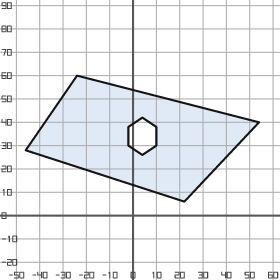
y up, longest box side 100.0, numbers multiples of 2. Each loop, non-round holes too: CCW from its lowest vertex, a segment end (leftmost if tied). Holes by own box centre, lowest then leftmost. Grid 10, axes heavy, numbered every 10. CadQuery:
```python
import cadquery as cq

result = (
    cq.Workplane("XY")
    .moveTo(22.0, 6.0)
    .lineTo(54.0, 40.0)
    .lineTo(-24.0, 60.0)
    .lineTo(-46.0, 28.0)
    .close()
    .moveTo(4.0, 26.0)
    .lineTo(10.0, 30.0)
    .lineTo(10.0, 38.0)
    .lineTo(4.0, 42.0)
    .lineTo(-2.0, 38.0)
    .lineTo(-2.0, 30.0)
    .close()
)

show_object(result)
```